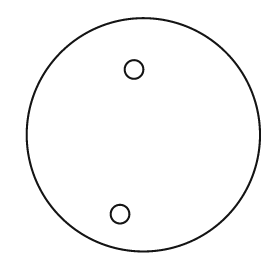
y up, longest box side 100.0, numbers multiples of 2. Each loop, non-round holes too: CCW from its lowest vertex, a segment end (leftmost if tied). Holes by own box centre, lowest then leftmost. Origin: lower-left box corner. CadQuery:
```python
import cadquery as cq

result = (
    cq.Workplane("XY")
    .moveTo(50.0, 50.0)
    .circle(50.0)
    .moveTo(40.0, 16.0)
    .circle(4.0)
    .moveTo(46.0, 78.0)
    .circle(4.0)
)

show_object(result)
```